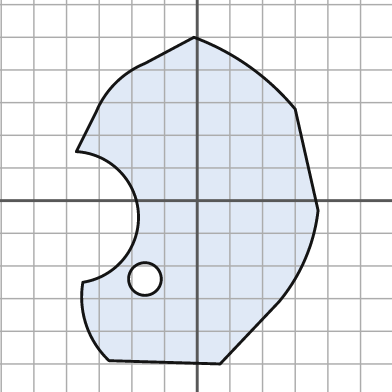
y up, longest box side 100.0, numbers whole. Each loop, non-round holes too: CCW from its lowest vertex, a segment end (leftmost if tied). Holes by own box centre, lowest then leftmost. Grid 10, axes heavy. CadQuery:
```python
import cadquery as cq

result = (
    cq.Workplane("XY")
    .moveTo(7.0, -50.0)
    .lineTo(25.0, -31.0)
    .threePointArc((33.0, -18.0), (37.0, -3.0))
    .lineTo(30.0, 28.0)
    .threePointArc((16.0, 41.0), (-1.0, 50.0))
    .lineTo(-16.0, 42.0)
    .threePointArc((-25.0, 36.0), (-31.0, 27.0))
    .lineTo(-37.0, 15.0)
    .threePointArc((-18.0, -4.0), (-35.0, -25.0))
    .threePointArc((-34.0, -38.0), (-27.0, -49.0))
    .close()
    .moveTo(-16.0, -24.0)
    .circle(5.0)
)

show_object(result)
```